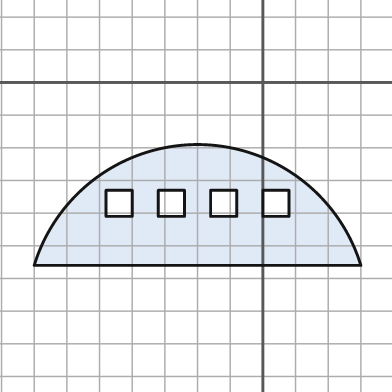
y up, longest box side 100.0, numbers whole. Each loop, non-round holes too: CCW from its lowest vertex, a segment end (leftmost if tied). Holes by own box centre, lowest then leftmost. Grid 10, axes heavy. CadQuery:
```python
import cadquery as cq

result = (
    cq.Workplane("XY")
    .moveTo(-70.0, -56.0)
    .lineTo(30.0, -56.0)
    .threePointArc((-20.0, -19.0), (-70.0, -56.0))
    .close()
    .moveTo(-48.0, -41.0)
    .lineTo(-40.0, -41.0)
    .lineTo(-40.0, -33.0)
    .lineTo(-48.0, -33.0)
    .close()
    .moveTo(-32.0, -41.0)
    .lineTo(-24.0, -41.0)
    .lineTo(-24.0, -33.0)
    .lineTo(-32.0, -33.0)
    .close()
    .moveTo(-16.0, -41.0)
    .lineTo(-8.0, -41.0)
    .lineTo(-8.0, -33.0)
    .lineTo(-16.0, -33.0)
    .close()
    .moveTo(0.0, -41.0)
    .lineTo(8.0, -41.0)
    .lineTo(8.0, -33.0)
    .lineTo(0.0, -33.0)
    .close()
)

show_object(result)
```